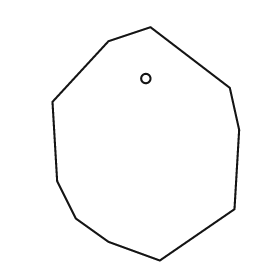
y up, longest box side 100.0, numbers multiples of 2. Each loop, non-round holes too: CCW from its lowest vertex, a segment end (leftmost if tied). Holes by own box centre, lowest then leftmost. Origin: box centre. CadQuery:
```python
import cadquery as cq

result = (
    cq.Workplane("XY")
    .moveTo(6.0, -50.0)
    .lineTo(38.0, -28.0)
    .lineTo(40.0, 6.0)
    .lineTo(36.0, 24.0)
    .lineTo(2.0, 50.0)
    .lineTo(-16.0, 44.0)
    .lineTo(-40.0, 18.0)
    .lineTo(-38.0, -16.0)
    .lineTo(-30.0, -32.0)
    .lineTo(-16.0, -42.0)
    .close()
    .moveTo(0.0, 28.0)
    .circle(2.0)
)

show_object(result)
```